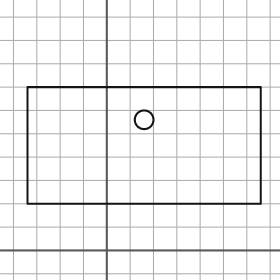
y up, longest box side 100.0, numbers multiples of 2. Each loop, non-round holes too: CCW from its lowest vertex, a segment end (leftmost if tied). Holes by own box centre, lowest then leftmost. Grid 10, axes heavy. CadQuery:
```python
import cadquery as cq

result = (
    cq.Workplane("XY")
    .moveTo(-34.0, 20.0)
    .lineTo(66.0, 20.0)
    .lineTo(66.0, 70.0)
    .lineTo(-34.0, 70.0)
    .close()
    .moveTo(16.0, 56.0)
    .circle(4.0)
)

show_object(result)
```